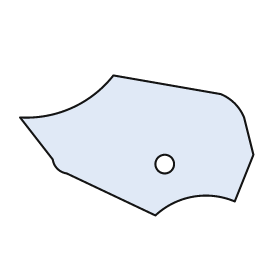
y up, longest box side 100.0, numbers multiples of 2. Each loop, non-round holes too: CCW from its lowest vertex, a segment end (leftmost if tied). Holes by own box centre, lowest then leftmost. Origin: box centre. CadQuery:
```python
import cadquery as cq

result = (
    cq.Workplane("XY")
    .moveTo(8.0, -30.0)
    .threePointArc((24.0, -22.0), (42.0, -24.0))
    .lineTo(50.0, -4.0)
    .lineTo(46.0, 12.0)
    .threePointArc((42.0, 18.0), (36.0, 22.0))
    .lineTo(-10.0, 30.0)
    .threePointArc((-28.0, 16.0), (-50.0, 12.0))
    .lineTo(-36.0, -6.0)
    .threePointArc((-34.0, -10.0), (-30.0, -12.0))
    .close()
    .moveTo(12.0, -8.0)
    .circle(4.0)
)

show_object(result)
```